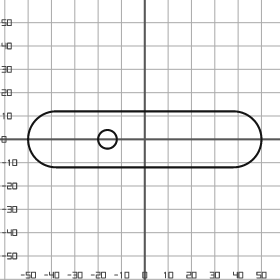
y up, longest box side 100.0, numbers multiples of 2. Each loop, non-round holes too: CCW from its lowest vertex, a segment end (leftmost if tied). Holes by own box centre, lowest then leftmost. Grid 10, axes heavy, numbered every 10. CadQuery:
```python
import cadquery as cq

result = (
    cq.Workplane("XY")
    .moveTo(-38.0, -12.0)
    .lineTo(38.0, -12.0)
    .threePointArc((50.0, 0.0), (38.0, 12.0))
    .lineTo(-38.0, 12.0)
    .threePointArc((-50.0, 0.0), (-38.0, -12.0))
    .close()
    .moveTo(-16.0, 0.0)
    .circle(4.0)
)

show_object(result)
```